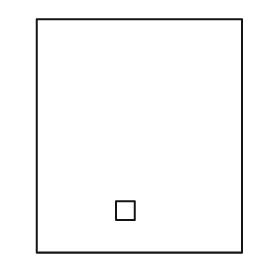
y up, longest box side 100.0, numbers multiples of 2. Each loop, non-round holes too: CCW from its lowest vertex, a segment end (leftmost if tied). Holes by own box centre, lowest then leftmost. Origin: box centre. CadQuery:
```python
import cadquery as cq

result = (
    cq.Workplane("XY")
    .moveTo(-44.0, -50.0)
    .lineTo(44.0, -50.0)
    .lineTo(44.0, 50.0)
    .lineTo(-44.0, 50.0)
    .close()
    .moveTo(-10.0, -36.0)
    .lineTo(-2.0, -36.0)
    .lineTo(-2.0, -28.0)
    .lineTo(-10.0, -28.0)
    .close()
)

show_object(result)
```